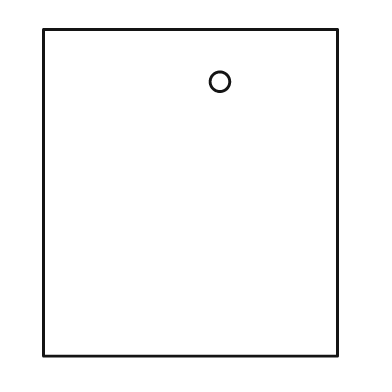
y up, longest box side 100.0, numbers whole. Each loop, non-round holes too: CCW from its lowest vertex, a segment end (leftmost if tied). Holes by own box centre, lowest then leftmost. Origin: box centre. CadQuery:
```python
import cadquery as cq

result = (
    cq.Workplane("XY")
    .moveTo(-45.0, -50.0)
    .lineTo(45.0, -50.0)
    .lineTo(45.0, 50.0)
    .lineTo(-45.0, 50.0)
    .close()
    .moveTo(9.0, 34.0)
    .circle(3.0)
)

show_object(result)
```